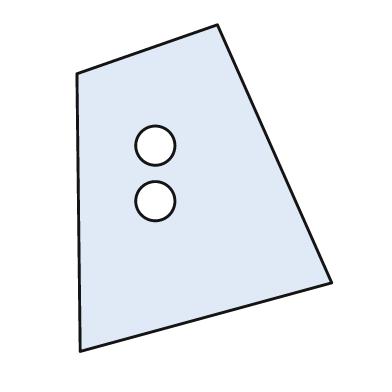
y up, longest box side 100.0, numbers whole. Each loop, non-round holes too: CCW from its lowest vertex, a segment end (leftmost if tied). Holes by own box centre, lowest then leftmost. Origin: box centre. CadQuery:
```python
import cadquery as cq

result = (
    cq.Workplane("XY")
    .moveTo(-38.0, -50.0)
    .lineTo(39.0, -29.0)
    .lineTo(4.0, 50.0)
    .lineTo(-39.0, 35.0)
    .close()
    .moveTo(-15.0, -4.0)
    .circle(6.0)
    .moveTo(-15.0, 13.0)
    .circle(6.0)
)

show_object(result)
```